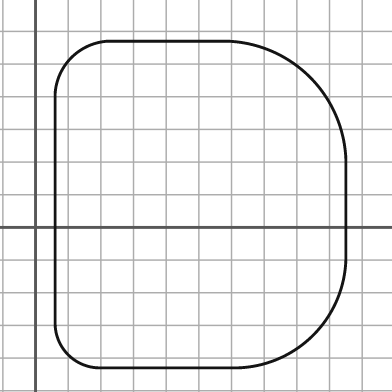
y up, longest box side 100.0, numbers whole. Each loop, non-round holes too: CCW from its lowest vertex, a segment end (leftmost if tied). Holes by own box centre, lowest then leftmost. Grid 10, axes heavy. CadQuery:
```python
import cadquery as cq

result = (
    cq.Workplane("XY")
    .moveTo(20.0, -43.0)
    .lineTo(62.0, -43.0)
    .threePointArc((85.0, -33.0), (95.0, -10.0))
    .lineTo(95.0, 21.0)
    .threePointArc((84.0, 46.0), (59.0, 57.0))
    .lineTo(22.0, 57.0)
    .threePointArc((11.0, 52.0), (6.0, 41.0))
    .lineTo(6.0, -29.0)
    .threePointArc((10.0, -39.0), (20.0, -43.0))
    .close()
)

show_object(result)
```